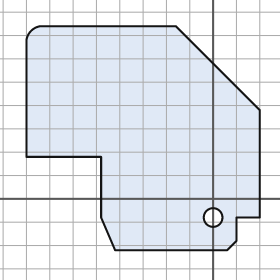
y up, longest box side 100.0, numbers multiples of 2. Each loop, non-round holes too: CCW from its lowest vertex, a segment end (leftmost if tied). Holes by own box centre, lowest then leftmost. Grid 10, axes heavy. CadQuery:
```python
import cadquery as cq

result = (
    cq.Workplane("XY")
    .moveTo(-42.0, -22.0)
    .lineTo(6.0, -22.0)
    .lineTo(10.0, -18.0)
    .lineTo(10.0, -8.0)
    .lineTo(20.0, -8.0)
    .lineTo(20.0, 38.0)
    .lineTo(-16.0, 74.0)
    .lineTo(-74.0, 74.0)
    .threePointArc((-78.0, 72.0), (-80.0, 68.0))
    .lineTo(-80.0, 18.0)
    .lineTo(-48.0, 18.0)
    .lineTo(-48.0, -8.0)
    .close()
    .moveTo(0.0, -8.0)
    .circle(4.0)
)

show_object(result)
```